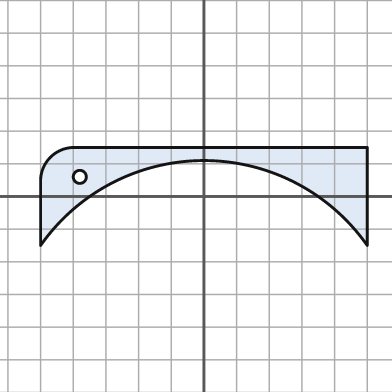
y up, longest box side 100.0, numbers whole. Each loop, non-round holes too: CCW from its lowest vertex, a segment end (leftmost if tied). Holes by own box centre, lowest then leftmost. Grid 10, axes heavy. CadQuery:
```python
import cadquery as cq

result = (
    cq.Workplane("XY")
    .moveTo(-50.0, -15.0)
    .threePointArc((0.0, 11.0), (50.0, -15.0))
    .lineTo(50.0, 15.0)
    .lineTo(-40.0, 15.0)
    .threePointArc((-47.0, 12.0), (-50.0, 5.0))
    .close()
    .moveTo(-38.0, 6.0)
    .circle(2.0)
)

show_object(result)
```